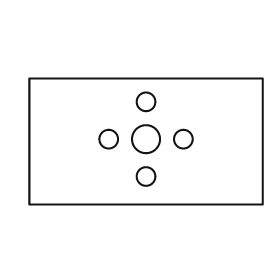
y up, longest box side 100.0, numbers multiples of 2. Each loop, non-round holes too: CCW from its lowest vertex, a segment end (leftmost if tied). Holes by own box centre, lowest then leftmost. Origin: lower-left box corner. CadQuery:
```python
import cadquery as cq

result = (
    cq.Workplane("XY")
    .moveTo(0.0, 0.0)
    .lineTo(100.0, 0.0)
    .lineTo(100.0, 54.0)
    .lineTo(0.0, 54.0)
    .close()
    .moveTo(50.0, 12.0)
    .circle(4.0)
    .moveTo(34.0, 28.0)
    .circle(4.0)
    .moveTo(50.0, 28.0)
    .circle(6.0)
    .moveTo(66.0, 28.0)
    .circle(4.0)
    .moveTo(50.0, 44.0)
    .circle(4.0)
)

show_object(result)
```